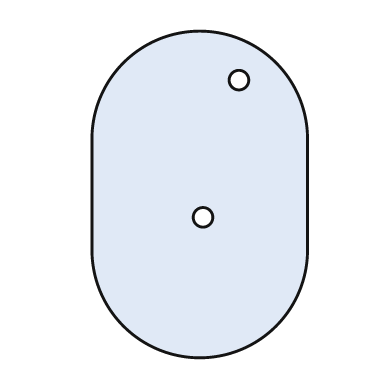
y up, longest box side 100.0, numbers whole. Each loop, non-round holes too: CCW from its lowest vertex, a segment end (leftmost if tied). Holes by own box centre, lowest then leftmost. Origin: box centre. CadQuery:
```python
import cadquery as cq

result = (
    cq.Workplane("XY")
    .moveTo(-33.0, -17.0)
    .threePointArc((0.0, -50.0), (33.0, -17.0))
    .lineTo(33.0, 17.0)
    .threePointArc((0.0, 50.0), (-33.0, 17.0))
    .close()
    .moveTo(1.0, -7.0)
    .circle(3.0)
    .moveTo(12.0, 35.0)
    .circle(3.0)
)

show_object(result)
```